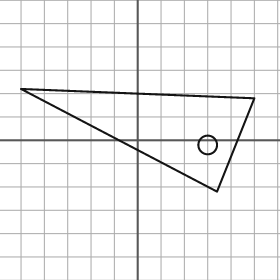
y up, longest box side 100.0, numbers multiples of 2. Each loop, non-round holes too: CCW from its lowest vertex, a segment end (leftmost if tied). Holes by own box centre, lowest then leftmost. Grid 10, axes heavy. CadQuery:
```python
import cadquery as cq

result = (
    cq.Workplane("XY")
    .moveTo(34.0, -22.0)
    .lineTo(50.0, 18.0)
    .lineTo(-50.0, 22.0)
    .close()
    .moveTo(30.0, -2.0)
    .circle(4.0)
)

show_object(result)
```